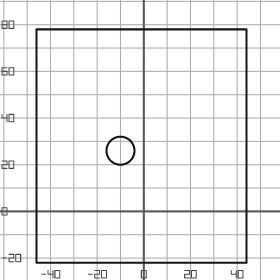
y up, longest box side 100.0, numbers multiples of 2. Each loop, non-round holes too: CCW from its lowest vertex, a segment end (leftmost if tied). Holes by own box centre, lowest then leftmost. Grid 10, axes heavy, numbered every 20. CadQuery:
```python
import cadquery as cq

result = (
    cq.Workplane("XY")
    .moveTo(-46.0, -22.0)
    .lineTo(44.0, -22.0)
    .lineTo(44.0, 78.0)
    .lineTo(-46.0, 78.0)
    .close()
    .moveTo(-10.0, 26.0)
    .circle(6.0)
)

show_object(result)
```